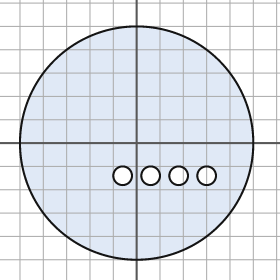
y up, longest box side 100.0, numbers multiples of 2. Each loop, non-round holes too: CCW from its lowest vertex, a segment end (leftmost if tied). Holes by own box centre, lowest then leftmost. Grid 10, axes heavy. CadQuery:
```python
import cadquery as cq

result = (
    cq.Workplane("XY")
    .moveTo(0.0, 0.0)
    .circle(50.0)
    .moveTo(-6.0, -14.0)
    .circle(4.0)
    .moveTo(6.0, -14.0)
    .circle(4.0)
    .moveTo(18.0, -14.0)
    .circle(4.0)
    .moveTo(30.0, -14.0)
    .circle(4.0)
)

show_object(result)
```